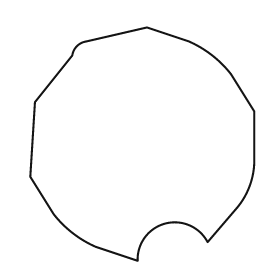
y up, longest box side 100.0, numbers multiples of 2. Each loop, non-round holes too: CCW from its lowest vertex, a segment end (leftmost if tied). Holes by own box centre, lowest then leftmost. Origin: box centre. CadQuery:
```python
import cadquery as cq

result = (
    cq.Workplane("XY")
    .moveTo(-2.0, -50.0)
    .threePointArc((10.0, -34.0), (28.0, -42.0))
    .lineTo(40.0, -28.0)
    .threePointArc((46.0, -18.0), (48.0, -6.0))
    .lineTo(48.0, 14.0)
    .lineTo(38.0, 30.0)
    .threePointArc((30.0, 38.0), (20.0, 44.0))
    .lineTo(2.0, 50.0)
    .lineTo(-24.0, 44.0)
    .threePointArc((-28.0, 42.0), (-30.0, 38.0))
    .lineTo(-46.0, 18.0)
    .lineTo(-48.0, -14.0)
    .lineTo(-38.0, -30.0)
    .threePointArc((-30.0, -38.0), (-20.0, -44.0))
    .close()
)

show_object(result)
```